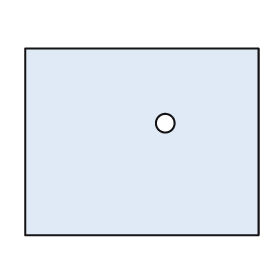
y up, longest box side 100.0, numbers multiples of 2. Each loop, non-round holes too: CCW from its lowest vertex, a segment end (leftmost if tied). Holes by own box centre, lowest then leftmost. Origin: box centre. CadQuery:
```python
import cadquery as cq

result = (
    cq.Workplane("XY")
    .moveTo(-50.0, -40.0)
    .lineTo(50.0, -40.0)
    .lineTo(50.0, 40.0)
    .lineTo(-50.0, 40.0)
    .close()
    .moveTo(10.0, 8.0)
    .circle(4.0)
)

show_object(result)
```